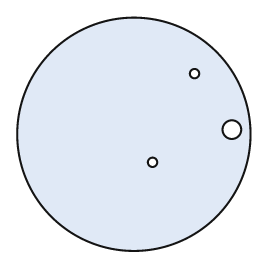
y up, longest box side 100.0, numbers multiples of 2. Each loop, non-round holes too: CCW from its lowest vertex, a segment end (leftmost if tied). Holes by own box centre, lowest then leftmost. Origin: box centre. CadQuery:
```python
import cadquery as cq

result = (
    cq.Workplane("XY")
    .moveTo(0.0, 0.0)
    .circle(50.0)
    .moveTo(8.0, -12.0)
    .circle(2.0)
    .moveTo(42.0, 2.0)
    .circle(4.0)
    .moveTo(26.0, 26.0)
    .circle(2.0)
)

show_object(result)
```